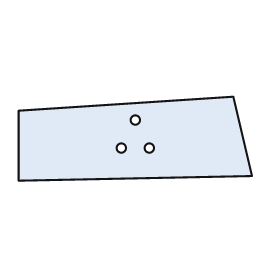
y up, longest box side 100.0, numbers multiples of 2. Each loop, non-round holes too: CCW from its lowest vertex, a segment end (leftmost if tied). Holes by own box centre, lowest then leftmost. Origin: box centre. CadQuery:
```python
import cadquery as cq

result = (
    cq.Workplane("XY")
    .moveTo(-50.0, -18.0)
    .lineTo(50.0, -16.0)
    .lineTo(42.0, 18.0)
    .lineTo(-50.0, 12.0)
    .close()
    .moveTo(-6.0, -4.0)
    .circle(2.0)
    .moveTo(6.0, -4.0)
    .circle(2.0)
    .moveTo(0.0, 8.0)
    .circle(2.0)
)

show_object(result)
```